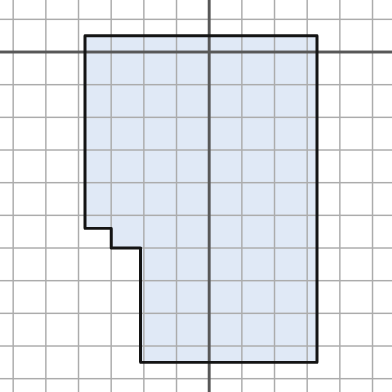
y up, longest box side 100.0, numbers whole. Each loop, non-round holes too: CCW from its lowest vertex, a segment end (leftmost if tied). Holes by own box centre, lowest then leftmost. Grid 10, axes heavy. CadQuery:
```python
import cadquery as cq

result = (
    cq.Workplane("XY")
    .moveTo(-21.0, -95.0)
    .lineTo(33.0, -95.0)
    .lineTo(33.0, 5.0)
    .lineTo(-38.0, 5.0)
    .lineTo(-38.0, -54.0)
    .lineTo(-30.0, -54.0)
    .lineTo(-30.0, -60.0)
    .lineTo(-21.0, -60.0)
    .close()
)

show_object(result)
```